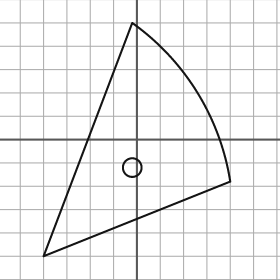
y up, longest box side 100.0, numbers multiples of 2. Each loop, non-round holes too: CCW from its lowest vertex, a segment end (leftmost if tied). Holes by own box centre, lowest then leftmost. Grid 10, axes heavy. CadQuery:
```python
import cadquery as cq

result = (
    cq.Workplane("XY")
    .moveTo(-40.0, -50.0)
    .lineTo(40.0, -18.0)
    .threePointArc((26.0, 20.0), (-2.0, 50.0))
    .close()
    .moveTo(-2.0, -12.0)
    .circle(4.0)
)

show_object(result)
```